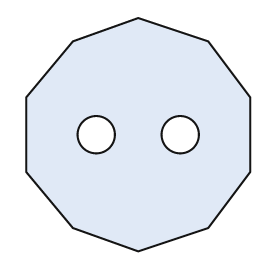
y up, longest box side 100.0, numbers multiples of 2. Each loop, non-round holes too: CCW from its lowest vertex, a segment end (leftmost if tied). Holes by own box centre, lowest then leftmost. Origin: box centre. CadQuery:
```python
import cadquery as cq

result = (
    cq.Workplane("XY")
    .moveTo(0.0, -50.0)
    .lineTo(30.0, -40.0)
    .lineTo(48.0, -16.0)
    .lineTo(48.0, 16.0)
    .lineTo(30.0, 40.0)
    .lineTo(0.0, 50.0)
    .lineTo(-28.0, 40.0)
    .lineTo(-48.0, 16.0)
    .lineTo(-48.0, -16.0)
    .lineTo(-28.0, -40.0)
    .close()
    .moveTo(-18.0, 0.0)
    .circle(8.0)
    .moveTo(18.0, 0.0)
    .circle(8.0)
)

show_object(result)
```